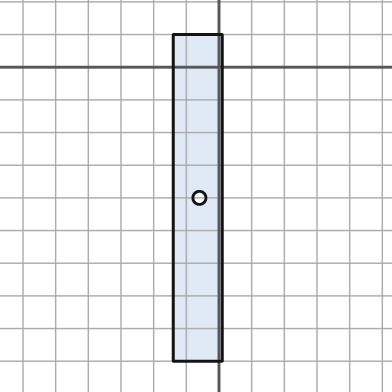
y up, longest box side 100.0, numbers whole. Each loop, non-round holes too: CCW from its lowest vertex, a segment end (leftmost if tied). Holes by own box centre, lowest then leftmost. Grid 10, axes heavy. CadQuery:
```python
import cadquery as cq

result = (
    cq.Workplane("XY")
    .moveTo(-14.0, -90.0)
    .lineTo(1.0, -90.0)
    .lineTo(1.0, 10.0)
    .lineTo(-14.0, 10.0)
    .close()
    .moveTo(-6.0, -40.0)
    .circle(2.0)
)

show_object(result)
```